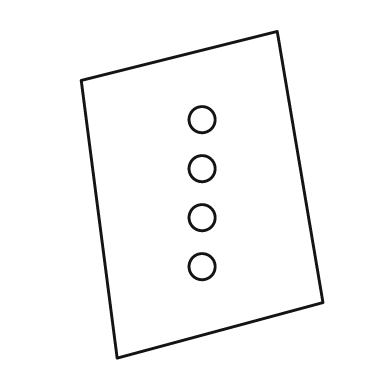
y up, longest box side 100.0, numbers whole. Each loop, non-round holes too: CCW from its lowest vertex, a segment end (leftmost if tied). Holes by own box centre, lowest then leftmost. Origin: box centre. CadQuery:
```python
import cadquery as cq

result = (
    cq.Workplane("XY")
    .moveTo(-26.0, -50.0)
    .lineTo(37.0, -33.0)
    .lineTo(23.0, 50.0)
    .lineTo(-37.0, 35.0)
    .close()
    .moveTo(0.0, -22.0)
    .circle(4.0)
    .moveTo(0.0, -7.0)
    .circle(4.0)
    .moveTo(0.0, 8.0)
    .circle(4.0)
    .moveTo(0.0, 23.0)
    .circle(4.0)
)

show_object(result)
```